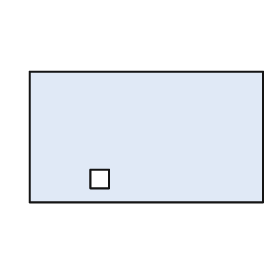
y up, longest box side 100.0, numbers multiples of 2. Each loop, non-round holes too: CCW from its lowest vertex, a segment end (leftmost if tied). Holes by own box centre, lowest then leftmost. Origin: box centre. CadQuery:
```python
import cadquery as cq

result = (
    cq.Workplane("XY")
    .moveTo(-50.0, -28.0)
    .lineTo(50.0, -28.0)
    .lineTo(50.0, 28.0)
    .lineTo(-50.0, 28.0)
    .close()
    .moveTo(-24.0, -22.0)
    .lineTo(-16.0, -22.0)
    .lineTo(-16.0, -14.0)
    .lineTo(-24.0, -14.0)
    .close()
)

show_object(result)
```